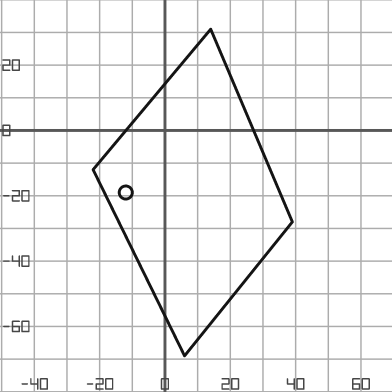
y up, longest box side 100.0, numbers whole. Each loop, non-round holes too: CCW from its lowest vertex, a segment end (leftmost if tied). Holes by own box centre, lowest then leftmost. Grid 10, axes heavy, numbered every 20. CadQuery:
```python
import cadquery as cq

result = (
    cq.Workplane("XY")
    .moveTo(6.0, -69.0)
    .lineTo(39.0, -28.0)
    .lineTo(14.0, 31.0)
    .lineTo(-22.0, -12.0)
    .close()
    .moveTo(-12.0, -19.0)
    .circle(2.0)
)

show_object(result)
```